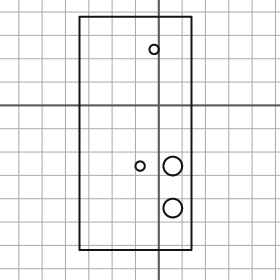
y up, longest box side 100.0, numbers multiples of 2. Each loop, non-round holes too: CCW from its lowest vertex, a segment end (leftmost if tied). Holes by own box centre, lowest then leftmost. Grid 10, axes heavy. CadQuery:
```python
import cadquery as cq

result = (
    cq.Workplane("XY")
    .moveTo(-34.0, -62.0)
    .lineTo(14.0, -62.0)
    .lineTo(14.0, 38.0)
    .lineTo(-34.0, 38.0)
    .close()
    .moveTo(6.0, -44.0)
    .circle(4.0)
    .moveTo(-8.0, -26.0)
    .circle(2.0)
    .moveTo(6.0, -26.0)
    .circle(4.0)
    .moveTo(-2.0, 24.0)
    .circle(2.0)
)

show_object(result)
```